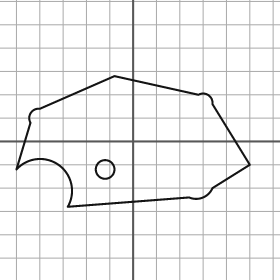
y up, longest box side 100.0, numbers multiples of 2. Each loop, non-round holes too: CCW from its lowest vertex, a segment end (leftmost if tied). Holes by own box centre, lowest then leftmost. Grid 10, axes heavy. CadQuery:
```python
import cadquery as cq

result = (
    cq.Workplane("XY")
    .moveTo(-28.0, -28.0)
    .lineTo(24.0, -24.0)
    .threePointArc((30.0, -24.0), (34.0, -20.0))
    .lineTo(50.0, -10.0)
    .lineTo(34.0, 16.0)
    .threePointArc((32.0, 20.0), (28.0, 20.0))
    .lineTo(-8.0, 28.0)
    .lineTo(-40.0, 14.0)
    .threePointArc((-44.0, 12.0), (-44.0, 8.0))
    .lineTo(-50.0, -12.0)
    .threePointArc((-32.0, -10.0), (-28.0, -28.0))
    .close()
    .moveTo(-12.0, -12.0)
    .circle(4.0)
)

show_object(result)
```